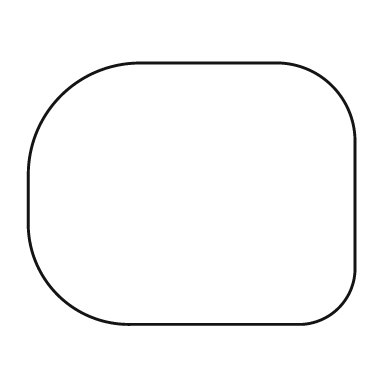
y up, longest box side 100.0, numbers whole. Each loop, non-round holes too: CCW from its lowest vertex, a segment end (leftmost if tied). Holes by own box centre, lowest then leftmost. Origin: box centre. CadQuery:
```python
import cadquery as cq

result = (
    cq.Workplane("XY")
    .moveTo(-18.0, -40.0)
    .lineTo(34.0, -40.0)
    .threePointArc((45.0, -35.0), (50.0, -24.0))
    .lineTo(50.0, 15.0)
    .threePointArc((43.0, 33.0), (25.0, 40.0))
    .lineTo(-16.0, 40.0)
    .threePointArc((-40.0, 30.0), (-50.0, 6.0))
    .lineTo(-50.0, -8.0)
    .threePointArc((-41.0, -31.0), (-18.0, -40.0))
    .close()
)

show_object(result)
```